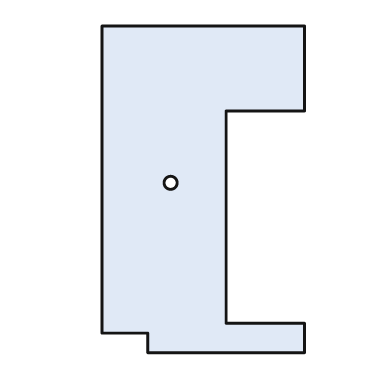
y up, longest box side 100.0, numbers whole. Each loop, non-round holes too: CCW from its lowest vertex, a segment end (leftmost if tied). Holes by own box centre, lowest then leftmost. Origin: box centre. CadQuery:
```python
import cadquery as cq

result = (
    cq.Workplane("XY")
    .moveTo(-17.0, -50.0)
    .lineTo(31.0, -50.0)
    .lineTo(31.0, -41.0)
    .lineTo(7.0, -41.0)
    .lineTo(7.0, 24.0)
    .lineTo(31.0, 24.0)
    .lineTo(31.0, 50.0)
    .lineTo(-31.0, 50.0)
    .lineTo(-31.0, -44.0)
    .lineTo(-17.0, -44.0)
    .close()
    .moveTo(-10.0, 2.0)
    .circle(2.0)
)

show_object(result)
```